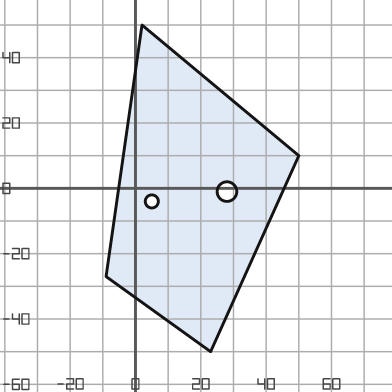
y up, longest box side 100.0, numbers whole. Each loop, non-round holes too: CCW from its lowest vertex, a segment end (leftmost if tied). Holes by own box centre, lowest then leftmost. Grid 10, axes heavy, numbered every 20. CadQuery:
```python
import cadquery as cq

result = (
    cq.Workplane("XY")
    .moveTo(23.0, -50.0)
    .lineTo(50.0, 10.0)
    .lineTo(2.0, 50.0)
    .lineTo(-9.0, -27.0)
    .close()
    .moveTo(5.0, -4.0)
    .circle(2.0)
    .moveTo(28.0, -1.0)
    .circle(3.0)
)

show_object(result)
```